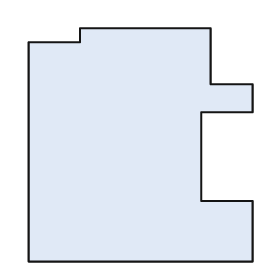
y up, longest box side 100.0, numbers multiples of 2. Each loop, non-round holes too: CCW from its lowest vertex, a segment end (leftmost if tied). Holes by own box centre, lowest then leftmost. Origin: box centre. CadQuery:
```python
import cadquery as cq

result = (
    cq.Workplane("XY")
    .moveTo(-48.0, -50.0)
    .lineTo(48.0, -50.0)
    .lineTo(48.0, -24.0)
    .lineTo(26.0, -24.0)
    .lineTo(26.0, 14.0)
    .lineTo(48.0, 14.0)
    .lineTo(48.0, 26.0)
    .lineTo(30.0, 26.0)
    .lineTo(30.0, 50.0)
    .lineTo(-26.0, 50.0)
    .lineTo(-26.0, 44.0)
    .lineTo(-48.0, 44.0)
    .close()
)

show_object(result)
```